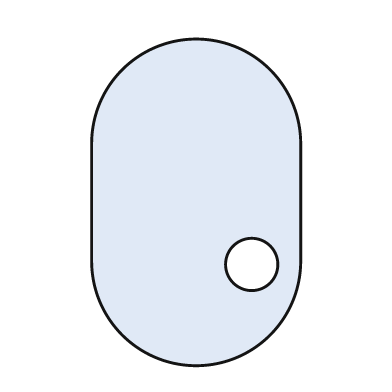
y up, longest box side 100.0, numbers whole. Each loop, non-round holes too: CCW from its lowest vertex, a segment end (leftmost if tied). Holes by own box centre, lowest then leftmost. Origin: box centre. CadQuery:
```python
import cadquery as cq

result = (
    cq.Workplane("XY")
    .moveTo(-32.0, -18.0)
    .threePointArc((0.0, -50.0), (32.0, -18.0))
    .lineTo(32.0, 18.0)
    .threePointArc((0.0, 50.0), (-32.0, 18.0))
    .close()
    .moveTo(17.0, -19.0)
    .circle(8.0)
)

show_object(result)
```